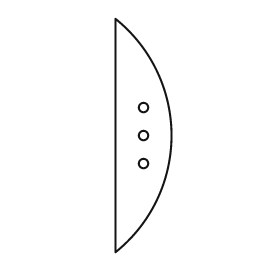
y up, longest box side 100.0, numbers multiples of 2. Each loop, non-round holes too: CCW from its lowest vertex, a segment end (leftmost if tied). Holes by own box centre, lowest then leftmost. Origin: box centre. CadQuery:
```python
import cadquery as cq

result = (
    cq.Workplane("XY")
    .moveTo(-12.0, -50.0)
    .threePointArc((12.0, 0.0), (-12.0, 50.0))
    .close()
    .moveTo(0.0, -12.0)
    .circle(2.0)
    .moveTo(0.0, 0.0)
    .circle(2.0)
    .moveTo(0.0, 12.0)
    .circle(2.0)
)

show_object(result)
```